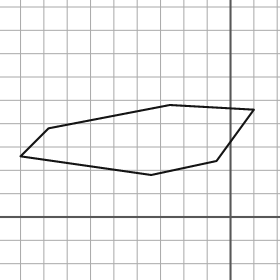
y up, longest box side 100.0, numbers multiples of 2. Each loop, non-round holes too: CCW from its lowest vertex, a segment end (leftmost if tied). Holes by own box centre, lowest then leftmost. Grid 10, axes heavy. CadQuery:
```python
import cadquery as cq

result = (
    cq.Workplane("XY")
    .moveTo(-34.0, 18.0)
    .lineTo(-6.0, 24.0)
    .lineTo(10.0, 46.0)
    .lineTo(-26.0, 48.0)
    .lineTo(-78.0, 38.0)
    .lineTo(-90.0, 26.0)
    .close()
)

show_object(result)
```